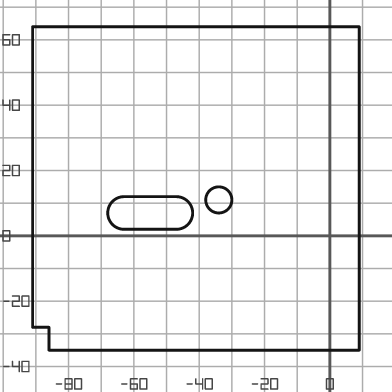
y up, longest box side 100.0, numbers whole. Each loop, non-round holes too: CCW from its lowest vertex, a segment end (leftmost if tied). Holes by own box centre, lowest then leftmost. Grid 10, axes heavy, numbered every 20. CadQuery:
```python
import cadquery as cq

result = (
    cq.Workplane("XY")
    .moveTo(-86.0, -35.0)
    .lineTo(9.0, -35.0)
    .lineTo(9.0, 64.0)
    .lineTo(-91.0, 64.0)
    .lineTo(-91.0, -28.0)
    .lineTo(-86.0, -28.0)
    .close()
    .moveTo(-63.0, 2.0)
    .lineTo(-47.0, 2.0)
    .threePointArc((-42.0, 7.0), (-47.0, 12.0))
    .lineTo(-63.0, 12.0)
    .threePointArc((-68.0, 7.0), (-63.0, 2.0))
    .close()
    .moveTo(-34.0, 11.0)
    .circle(4.0)
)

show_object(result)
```